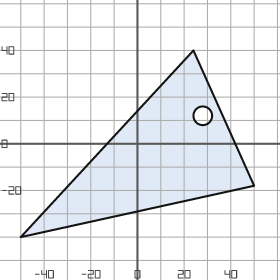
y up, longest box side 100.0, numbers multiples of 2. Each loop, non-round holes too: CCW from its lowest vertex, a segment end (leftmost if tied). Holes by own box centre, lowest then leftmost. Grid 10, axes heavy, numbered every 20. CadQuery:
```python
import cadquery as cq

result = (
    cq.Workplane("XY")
    .moveTo(-50.0, -40.0)
    .lineTo(50.0, -18.0)
    .lineTo(24.0, 40.0)
    .close()
    .moveTo(28.0, 12.0)
    .circle(4.0)
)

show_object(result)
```